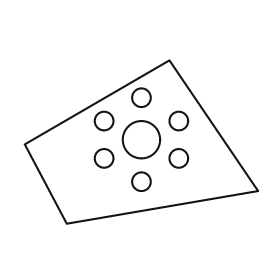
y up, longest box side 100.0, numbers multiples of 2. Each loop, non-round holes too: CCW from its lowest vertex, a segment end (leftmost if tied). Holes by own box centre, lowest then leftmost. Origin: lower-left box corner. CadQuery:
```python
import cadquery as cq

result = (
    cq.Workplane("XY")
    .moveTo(18.0, 0.0)
    .lineTo(100.0, 14.0)
    .lineTo(62.0, 70.0)
    .lineTo(0.0, 34.0)
    .close()
    .moveTo(50.0, 18.0)
    .circle(4.0)
    .moveTo(34.0, 28.0)
    .circle(4.0)
    .moveTo(66.0, 28.0)
    .circle(4.0)
    .moveTo(50.0, 36.0)
    .circle(8.0)
    .moveTo(34.0, 44.0)
    .circle(4.0)
    .moveTo(66.0, 44.0)
    .circle(4.0)
    .moveTo(50.0, 54.0)
    .circle(4.0)
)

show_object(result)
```